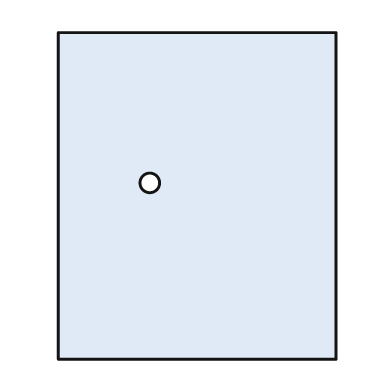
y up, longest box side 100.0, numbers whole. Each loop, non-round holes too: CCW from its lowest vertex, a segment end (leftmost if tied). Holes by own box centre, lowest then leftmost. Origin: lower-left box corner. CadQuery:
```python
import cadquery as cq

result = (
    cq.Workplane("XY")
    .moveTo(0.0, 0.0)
    .lineTo(85.0, 0.0)
    .lineTo(85.0, 100.0)
    .lineTo(0.0, 100.0)
    .close()
    .moveTo(28.0, 54.0)
    .circle(3.0)
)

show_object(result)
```